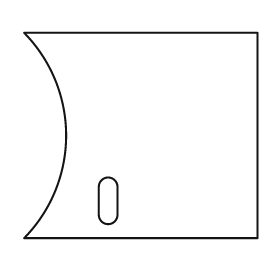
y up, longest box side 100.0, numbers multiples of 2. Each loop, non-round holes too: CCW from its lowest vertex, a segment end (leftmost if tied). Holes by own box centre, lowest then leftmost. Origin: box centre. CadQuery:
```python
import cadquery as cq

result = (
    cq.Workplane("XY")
    .moveTo(-50.0, -44.0)
    .lineTo(50.0, -44.0)
    .lineTo(50.0, 44.0)
    .lineTo(-50.0, 44.0)
    .threePointArc((-32.0, 0.0), (-50.0, -44.0))
    .close()
    .moveTo(-18.0, -34.0)
    .threePointArc((-14.0, -38.0), (-10.0, -34.0))
    .lineTo(-10.0, -22.0)
    .threePointArc((-14.0, -18.0), (-18.0, -22.0))
    .close()
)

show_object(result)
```